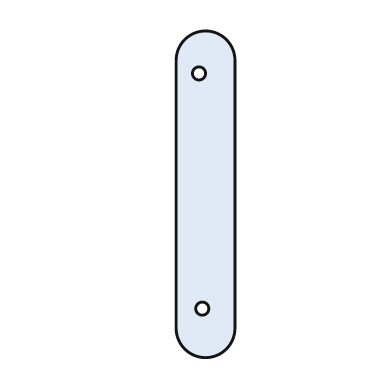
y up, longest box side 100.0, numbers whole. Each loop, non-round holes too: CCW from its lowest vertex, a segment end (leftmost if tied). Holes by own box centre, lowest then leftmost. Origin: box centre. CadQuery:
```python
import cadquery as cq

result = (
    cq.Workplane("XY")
    .moveTo(-9.0, -41.0)
    .threePointArc((0.0, -50.0), (9.0, -41.0))
    .lineTo(9.0, 41.0)
    .threePointArc((0.0, 50.0), (-9.0, 41.0))
    .close()
    .moveTo(-1.0, -35.0)
    .circle(2.0)
    .moveTo(-2.0, 37.0)
    .circle(2.0)
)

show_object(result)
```